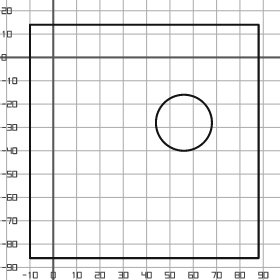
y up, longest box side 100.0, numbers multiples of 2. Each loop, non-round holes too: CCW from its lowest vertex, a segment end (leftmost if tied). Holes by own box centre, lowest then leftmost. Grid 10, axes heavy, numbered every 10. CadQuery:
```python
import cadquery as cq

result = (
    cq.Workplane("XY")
    .moveTo(-10.0, -86.0)
    .lineTo(88.0, -86.0)
    .lineTo(88.0, 14.0)
    .lineTo(-10.0, 14.0)
    .close()
    .moveTo(56.0, -28.0)
    .circle(12.0)
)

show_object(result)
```